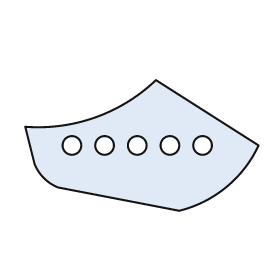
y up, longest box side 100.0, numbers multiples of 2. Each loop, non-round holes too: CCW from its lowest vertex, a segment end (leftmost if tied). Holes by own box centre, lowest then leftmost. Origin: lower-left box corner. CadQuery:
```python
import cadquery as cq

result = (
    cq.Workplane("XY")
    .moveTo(66.0, 0.0)
    .threePointArc((86.0, 10.0), (100.0, 28.0))
    .lineTo(56.0, 56.0)
    .threePointArc((30.0, 40.0), (0.0, 36.0))
    .lineTo(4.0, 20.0)
    .threePointArc((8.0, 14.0), (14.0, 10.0))
    .close()
    .moveTo(20.0, 28.0)
    .circle(4.0)
    .moveTo(34.0, 28.0)
    .circle(4.0)
    .moveTo(48.0, 28.0)
    .circle(4.0)
    .moveTo(62.0, 28.0)
    .circle(4.0)
    .moveTo(76.0, 28.0)
    .circle(4.0)
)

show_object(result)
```